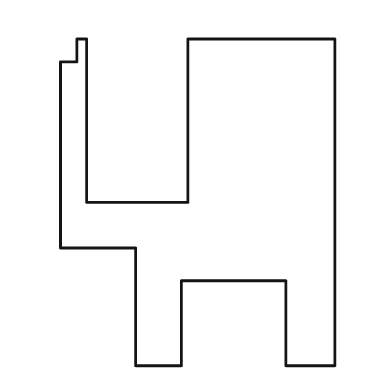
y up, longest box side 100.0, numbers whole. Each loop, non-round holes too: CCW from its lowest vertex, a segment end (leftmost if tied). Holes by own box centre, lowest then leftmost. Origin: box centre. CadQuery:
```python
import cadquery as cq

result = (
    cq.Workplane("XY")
    .moveTo(-19.0, -50.0)
    .lineTo(-5.0, -50.0)
    .lineTo(-5.0, -24.0)
    .lineTo(27.0, -24.0)
    .lineTo(27.0, -50.0)
    .lineTo(42.0, -50.0)
    .lineTo(42.0, 50.0)
    .lineTo(-3.0, 50.0)
    .lineTo(-3.0, 0.0)
    .lineTo(-34.0, 0.0)
    .lineTo(-34.0, 50.0)
    .lineTo(-37.0, 50.0)
    .lineTo(-37.0, 43.0)
    .lineTo(-42.0, 43.0)
    .lineTo(-42.0, -14.0)
    .lineTo(-19.0, -14.0)
    .close()
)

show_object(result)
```